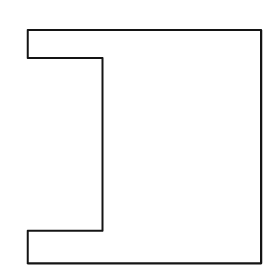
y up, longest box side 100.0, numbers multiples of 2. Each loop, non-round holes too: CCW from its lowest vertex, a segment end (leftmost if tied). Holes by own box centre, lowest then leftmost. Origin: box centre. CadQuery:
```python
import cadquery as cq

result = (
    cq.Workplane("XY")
    .moveTo(-50.0, -50.0)
    .lineTo(50.0, -50.0)
    .lineTo(50.0, 50.0)
    .lineTo(-50.0, 50.0)
    .lineTo(-50.0, 38.0)
    .lineTo(-18.0, 38.0)
    .lineTo(-18.0, -36.0)
    .lineTo(-50.0, -36.0)
    .close()
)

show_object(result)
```